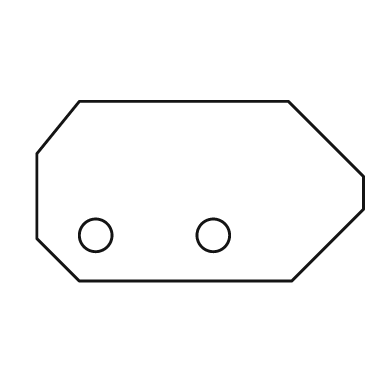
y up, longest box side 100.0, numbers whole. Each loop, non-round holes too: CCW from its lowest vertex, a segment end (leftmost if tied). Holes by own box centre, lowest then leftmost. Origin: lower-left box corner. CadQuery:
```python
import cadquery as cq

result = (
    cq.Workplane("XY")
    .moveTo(13.0, 0.0)
    .lineTo(78.0, 0.0)
    .lineTo(100.0, 22.0)
    .lineTo(100.0, 32.0)
    .lineTo(77.0, 55.0)
    .lineTo(13.0, 55.0)
    .lineTo(0.0, 39.0)
    .lineTo(0.0, 13.0)
    .close()
    .moveTo(18.0, 14.0)
    .circle(5.0)
    .moveTo(54.0, 14.0)
    .circle(5.0)
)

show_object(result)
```